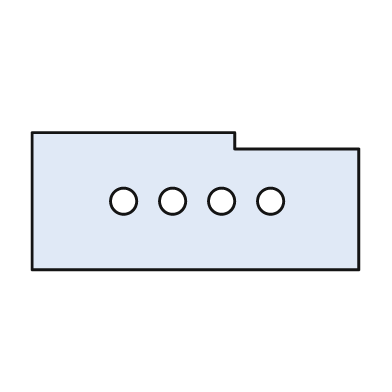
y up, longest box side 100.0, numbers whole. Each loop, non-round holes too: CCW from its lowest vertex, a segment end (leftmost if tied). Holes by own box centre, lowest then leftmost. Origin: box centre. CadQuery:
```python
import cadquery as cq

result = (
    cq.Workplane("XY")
    .moveTo(-50.0, -21.0)
    .lineTo(50.0, -21.0)
    .lineTo(50.0, 16.0)
    .lineTo(12.0, 16.0)
    .lineTo(12.0, 21.0)
    .lineTo(-50.0, 21.0)
    .close()
    .moveTo(-22.0, 0.0)
    .circle(4.0)
    .moveTo(-7.0, 0.0)
    .circle(4.0)
    .moveTo(8.0, 0.0)
    .circle(4.0)
    .moveTo(23.0, 0.0)
    .circle(4.0)
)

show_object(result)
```